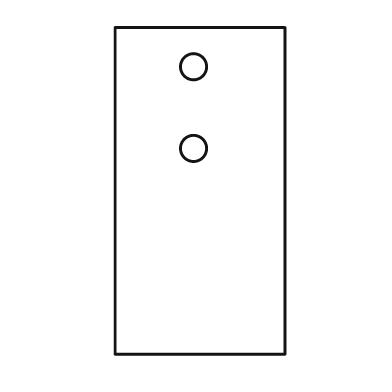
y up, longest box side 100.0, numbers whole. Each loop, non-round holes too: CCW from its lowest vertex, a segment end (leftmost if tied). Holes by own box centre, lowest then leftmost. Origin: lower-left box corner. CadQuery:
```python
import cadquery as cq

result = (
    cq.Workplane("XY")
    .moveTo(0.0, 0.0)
    .lineTo(52.0, 0.0)
    .lineTo(52.0, 100.0)
    .lineTo(0.0, 100.0)
    .close()
    .moveTo(24.0, 63.0)
    .circle(4.0)
    .moveTo(24.0, 88.0)
    .circle(4.0)
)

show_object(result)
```